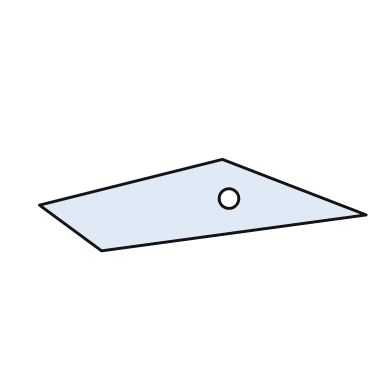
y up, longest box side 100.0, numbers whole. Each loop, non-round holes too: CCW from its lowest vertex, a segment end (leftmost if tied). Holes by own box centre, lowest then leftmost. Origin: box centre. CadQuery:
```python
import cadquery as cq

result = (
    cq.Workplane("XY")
    .moveTo(-31.0, -14.0)
    .lineTo(50.0, -3.0)
    .lineTo(6.0, 14.0)
    .lineTo(-50.0, 0.0)
    .close()
    .moveTo(8.0, 2.0)
    .circle(3.0)
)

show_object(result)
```